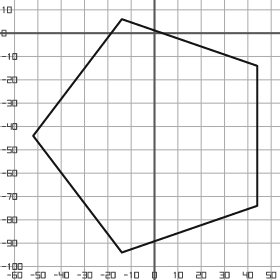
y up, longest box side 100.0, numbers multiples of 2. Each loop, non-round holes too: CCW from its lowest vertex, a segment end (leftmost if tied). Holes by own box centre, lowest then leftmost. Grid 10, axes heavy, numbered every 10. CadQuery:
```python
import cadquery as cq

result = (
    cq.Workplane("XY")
    .moveTo(-14.0, -94.0)
    .lineTo(44.0, -74.0)
    .lineTo(44.0, -14.0)
    .lineTo(-14.0, 6.0)
    .lineTo(-52.0, -44.0)
    .close()
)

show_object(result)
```